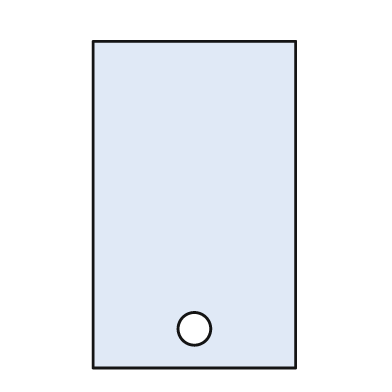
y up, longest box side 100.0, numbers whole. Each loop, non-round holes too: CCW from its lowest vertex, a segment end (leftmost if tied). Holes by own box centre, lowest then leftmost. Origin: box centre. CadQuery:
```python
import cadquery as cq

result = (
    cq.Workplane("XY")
    .moveTo(-31.0, -50.0)
    .lineTo(31.0, -50.0)
    .lineTo(31.0, 50.0)
    .lineTo(-31.0, 50.0)
    .close()
    .moveTo(0.0, -38.0)
    .circle(5.0)
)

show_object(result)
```